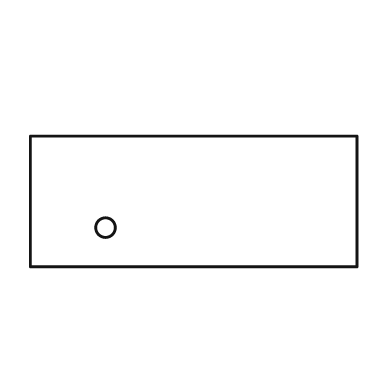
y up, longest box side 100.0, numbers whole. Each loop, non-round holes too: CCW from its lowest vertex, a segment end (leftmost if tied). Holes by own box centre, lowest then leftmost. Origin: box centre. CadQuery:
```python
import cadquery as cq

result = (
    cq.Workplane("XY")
    .moveTo(-50.0, -20.0)
    .lineTo(50.0, -20.0)
    .lineTo(50.0, 20.0)
    .lineTo(-50.0, 20.0)
    .close()
    .moveTo(-27.0, -8.0)
    .circle(3.0)
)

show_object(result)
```